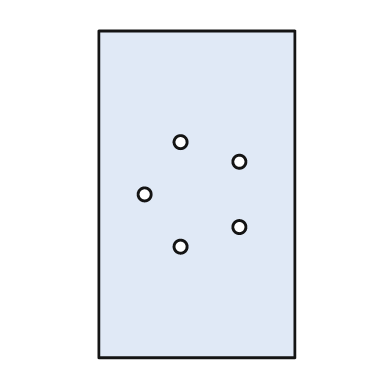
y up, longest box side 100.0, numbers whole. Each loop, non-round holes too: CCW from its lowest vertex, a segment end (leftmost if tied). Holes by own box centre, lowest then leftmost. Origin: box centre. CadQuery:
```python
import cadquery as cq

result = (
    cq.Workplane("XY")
    .moveTo(-30.0, -50.0)
    .lineTo(30.0, -50.0)
    .lineTo(30.0, 50.0)
    .lineTo(-30.0, 50.0)
    .close()
    .moveTo(-5.0, -16.0)
    .circle(2.0)
    .moveTo(13.0, -10.0)
    .circle(2.0)
    .moveTo(-16.0, 0.0)
    .circle(2.0)
    .moveTo(13.0, 10.0)
    .circle(2.0)
    .moveTo(-5.0, 16.0)
    .circle(2.0)
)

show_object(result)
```